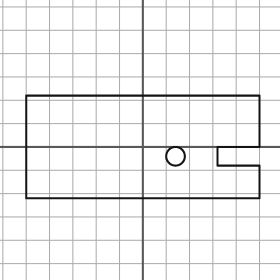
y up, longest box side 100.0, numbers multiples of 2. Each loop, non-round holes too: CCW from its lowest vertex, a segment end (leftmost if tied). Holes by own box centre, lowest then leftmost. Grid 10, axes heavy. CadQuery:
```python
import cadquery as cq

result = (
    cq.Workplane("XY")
    .moveTo(-50.0, -22.0)
    .lineTo(50.0, -22.0)
    .lineTo(50.0, -8.0)
    .lineTo(32.0, -8.0)
    .lineTo(32.0, 0.0)
    .lineTo(50.0, 0.0)
    .lineTo(50.0, 22.0)
    .lineTo(-50.0, 22.0)
    .close()
    .moveTo(14.0, -4.0)
    .circle(4.0)
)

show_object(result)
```